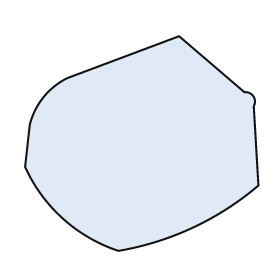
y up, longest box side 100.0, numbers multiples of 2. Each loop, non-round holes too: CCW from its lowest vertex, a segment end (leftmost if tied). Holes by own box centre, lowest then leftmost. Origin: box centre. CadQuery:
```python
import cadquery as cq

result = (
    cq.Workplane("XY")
    .moveTo(-10.0, -46.0)
    .threePointArc((22.0, -36.0), (50.0, -18.0))
    .lineTo(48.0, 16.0)
    .threePointArc((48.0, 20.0), (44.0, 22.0))
    .lineTo(16.0, 46.0)
    .lineTo(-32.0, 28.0)
    .threePointArc((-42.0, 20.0), (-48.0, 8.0))
    .lineTo(-50.0, -10.0)
    .threePointArc((-34.0, -32.0), (-10.0, -46.0))
    .close()
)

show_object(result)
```